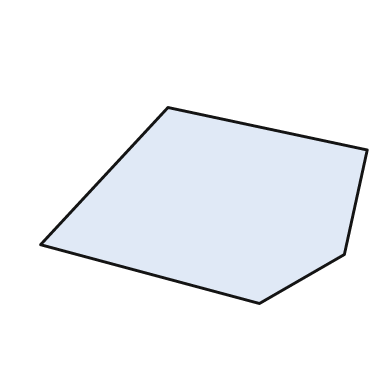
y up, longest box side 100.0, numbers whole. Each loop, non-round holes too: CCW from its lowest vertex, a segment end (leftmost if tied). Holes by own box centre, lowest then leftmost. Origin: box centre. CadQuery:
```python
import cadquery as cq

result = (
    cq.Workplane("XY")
    .moveTo(17.0, -30.0)
    .lineTo(43.0, -15.0)
    .lineTo(50.0, 17.0)
    .lineTo(-11.0, 30.0)
    .lineTo(-50.0, -12.0)
    .close()
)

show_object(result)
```